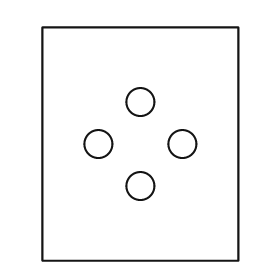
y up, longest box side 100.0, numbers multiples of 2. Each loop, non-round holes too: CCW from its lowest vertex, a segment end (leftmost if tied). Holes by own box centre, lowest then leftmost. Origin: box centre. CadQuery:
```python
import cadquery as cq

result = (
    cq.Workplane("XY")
    .moveTo(-42.0, -50.0)
    .lineTo(42.0, -50.0)
    .lineTo(42.0, 50.0)
    .lineTo(-42.0, 50.0)
    .close()
    .moveTo(0.0, -18.0)
    .circle(6.0)
    .moveTo(-18.0, 0.0)
    .circle(6.0)
    .moveTo(18.0, 0.0)
    .circle(6.0)
    .moveTo(0.0, 18.0)
    .circle(6.0)
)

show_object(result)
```